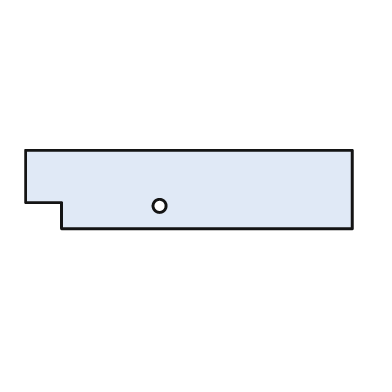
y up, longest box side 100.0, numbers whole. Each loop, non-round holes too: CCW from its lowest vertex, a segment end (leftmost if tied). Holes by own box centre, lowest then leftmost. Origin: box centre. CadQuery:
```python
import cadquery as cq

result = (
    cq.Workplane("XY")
    .moveTo(-39.0, -12.0)
    .lineTo(50.0, -12.0)
    .lineTo(50.0, 12.0)
    .lineTo(-50.0, 12.0)
    .lineTo(-50.0, -4.0)
    .lineTo(-39.0, -4.0)
    .close()
    .moveTo(-9.0, -5.0)
    .circle(2.0)
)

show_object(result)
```